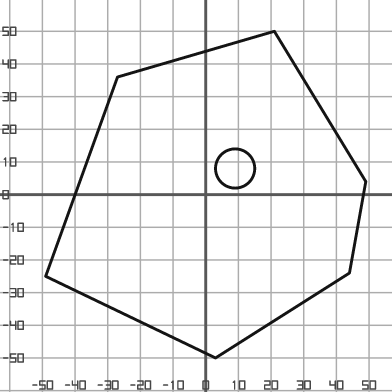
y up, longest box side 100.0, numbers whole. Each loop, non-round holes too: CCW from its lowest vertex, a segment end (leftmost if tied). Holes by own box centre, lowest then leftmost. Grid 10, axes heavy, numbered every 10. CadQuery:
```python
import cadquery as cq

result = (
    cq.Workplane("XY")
    .moveTo(3.0, -50.0)
    .lineTo(44.0, -24.0)
    .lineTo(49.0, 4.0)
    .lineTo(21.0, 50.0)
    .lineTo(-27.0, 36.0)
    .lineTo(-49.0, -25.0)
    .close()
    .moveTo(9.0, 8.0)
    .circle(6.0)
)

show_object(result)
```